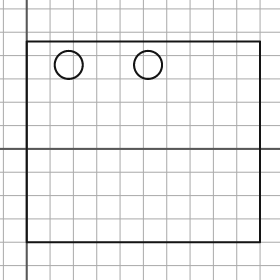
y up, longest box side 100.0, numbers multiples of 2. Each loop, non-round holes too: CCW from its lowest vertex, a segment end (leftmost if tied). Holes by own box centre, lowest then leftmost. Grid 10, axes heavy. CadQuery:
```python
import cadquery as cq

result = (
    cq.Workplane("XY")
    .moveTo(0.0, -40.0)
    .lineTo(100.0, -40.0)
    .lineTo(100.0, 46.0)
    .lineTo(0.0, 46.0)
    .close()
    .moveTo(18.0, 36.0)
    .circle(6.0)
    .moveTo(52.0, 36.0)
    .circle(6.0)
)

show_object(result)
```